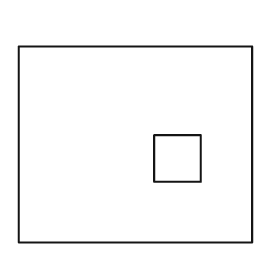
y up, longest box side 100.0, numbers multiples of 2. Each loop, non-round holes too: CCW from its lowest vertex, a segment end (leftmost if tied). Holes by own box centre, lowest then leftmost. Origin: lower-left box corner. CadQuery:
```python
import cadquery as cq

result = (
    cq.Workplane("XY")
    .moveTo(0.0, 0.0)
    .lineTo(100.0, 0.0)
    .lineTo(100.0, 84.0)
    .lineTo(0.0, 84.0)
    .close()
    .moveTo(58.0, 26.0)
    .lineTo(78.0, 26.0)
    .lineTo(78.0, 46.0)
    .lineTo(58.0, 46.0)
    .close()
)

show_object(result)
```